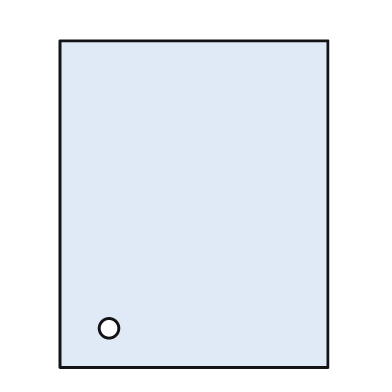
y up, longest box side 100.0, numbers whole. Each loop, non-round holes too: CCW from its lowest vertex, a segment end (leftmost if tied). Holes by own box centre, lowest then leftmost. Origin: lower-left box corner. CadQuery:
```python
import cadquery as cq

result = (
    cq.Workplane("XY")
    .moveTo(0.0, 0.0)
    .lineTo(82.0, 0.0)
    .lineTo(82.0, 100.0)
    .lineTo(0.0, 100.0)
    .close()
    .moveTo(15.0, 12.0)
    .circle(3.0)
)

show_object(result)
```